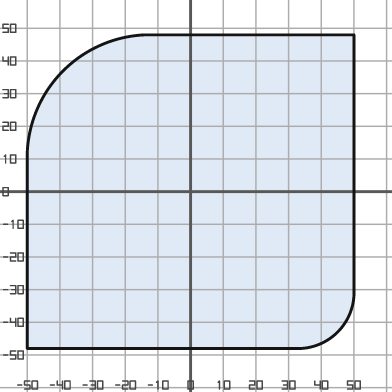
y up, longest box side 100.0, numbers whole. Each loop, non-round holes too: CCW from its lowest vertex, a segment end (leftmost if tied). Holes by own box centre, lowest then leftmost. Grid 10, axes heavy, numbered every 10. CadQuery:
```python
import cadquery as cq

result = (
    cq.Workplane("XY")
    .moveTo(-50.0, -48.0)
    .lineTo(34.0, -48.0)
    .threePointArc((45.0, -43.0), (50.0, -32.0))
    .lineTo(50.0, 48.0)
    .lineTo(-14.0, 48.0)
    .threePointArc((-39.0, 37.0), (-50.0, 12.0))
    .close()
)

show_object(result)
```